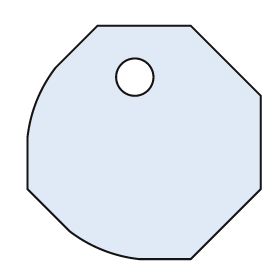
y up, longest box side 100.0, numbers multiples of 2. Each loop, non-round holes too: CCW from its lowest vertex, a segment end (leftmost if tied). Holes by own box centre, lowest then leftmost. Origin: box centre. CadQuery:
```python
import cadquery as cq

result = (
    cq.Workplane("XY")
    .moveTo(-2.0, -50.0)
    .lineTo(20.0, -50.0)
    .lineTo(50.0, -20.0)
    .lineTo(50.0, 20.0)
    .lineTo(20.0, 50.0)
    .lineTo(-20.0, 50.0)
    .lineTo(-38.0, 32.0)
    .threePointArc((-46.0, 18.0), (-50.0, 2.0))
    .lineTo(-50.0, -20.0)
    .lineTo(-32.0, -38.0)
    .threePointArc((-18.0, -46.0), (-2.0, -50.0))
    .close()
    .moveTo(-4.0, 28.0)
    .circle(8.0)
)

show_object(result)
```